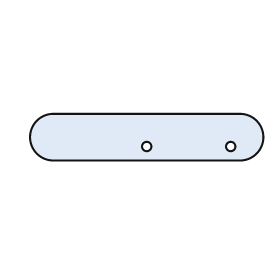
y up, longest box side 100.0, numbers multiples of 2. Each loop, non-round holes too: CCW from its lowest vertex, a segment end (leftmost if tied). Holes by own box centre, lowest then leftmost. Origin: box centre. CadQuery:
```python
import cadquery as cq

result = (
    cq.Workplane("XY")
    .moveTo(-40.0, -10.0)
    .lineTo(40.0, -10.0)
    .threePointArc((50.0, 0.0), (40.0, 10.0))
    .lineTo(-40.0, 10.0)
    .threePointArc((-50.0, 0.0), (-40.0, -10.0))
    .close()
    .moveTo(0.0, -4.0)
    .circle(2.0)
    .moveTo(36.0, -4.0)
    .circle(2.0)
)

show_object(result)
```